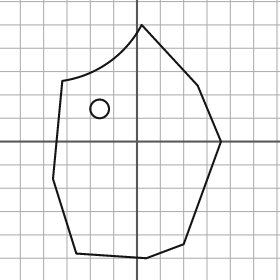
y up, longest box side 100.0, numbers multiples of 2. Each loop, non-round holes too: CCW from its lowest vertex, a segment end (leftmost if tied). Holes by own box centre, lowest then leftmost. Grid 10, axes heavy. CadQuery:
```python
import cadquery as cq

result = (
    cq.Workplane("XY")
    .moveTo(4.0, -50.0)
    .lineTo(20.0, -44.0)
    .lineTo(36.0, 0.0)
    .lineTo(26.0, 24.0)
    .lineTo(2.0, 50.0)
    .threePointArc((-12.0, 34.0), (-32.0, 26.0))
    .lineTo(-36.0, -16.0)
    .lineTo(-26.0, -48.0)
    .close()
    .moveTo(-16.0, 14.0)
    .circle(4.0)
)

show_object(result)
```